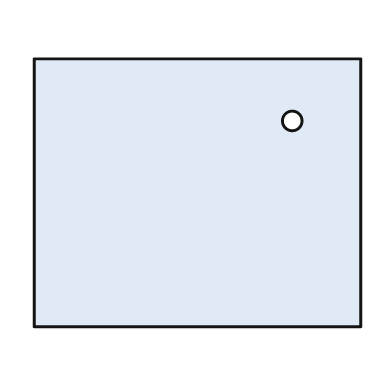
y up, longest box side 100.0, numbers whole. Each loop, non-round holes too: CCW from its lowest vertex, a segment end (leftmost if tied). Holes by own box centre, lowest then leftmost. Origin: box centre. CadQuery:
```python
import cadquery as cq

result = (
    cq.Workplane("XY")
    .moveTo(-50.0, -41.0)
    .lineTo(50.0, -41.0)
    .lineTo(50.0, 41.0)
    .lineTo(-50.0, 41.0)
    .close()
    .moveTo(29.0, 22.0)
    .circle(3.0)
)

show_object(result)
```